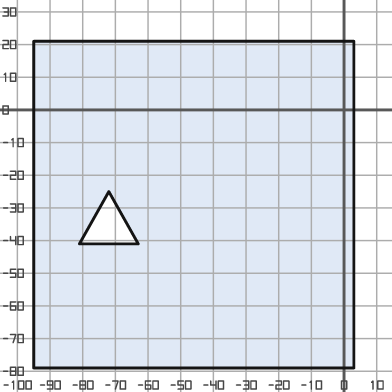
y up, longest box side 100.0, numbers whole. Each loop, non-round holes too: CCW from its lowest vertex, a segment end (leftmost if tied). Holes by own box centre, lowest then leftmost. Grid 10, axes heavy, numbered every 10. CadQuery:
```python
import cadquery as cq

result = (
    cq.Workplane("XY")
    .moveTo(-95.0, -79.0)
    .lineTo(3.0, -79.0)
    .lineTo(3.0, 21.0)
    .lineTo(-95.0, 21.0)
    .close()
    .moveTo(-81.0, -41.0)
    .lineTo(-63.0, -41.0)
    .lineTo(-72.0, -25.0)
    .close()
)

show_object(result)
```